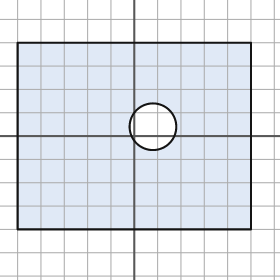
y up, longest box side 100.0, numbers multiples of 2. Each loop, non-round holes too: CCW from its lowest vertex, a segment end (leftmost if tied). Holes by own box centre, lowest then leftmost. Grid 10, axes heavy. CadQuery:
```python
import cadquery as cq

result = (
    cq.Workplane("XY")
    .moveTo(-50.0, -40.0)
    .lineTo(50.0, -40.0)
    .lineTo(50.0, 40.0)
    .lineTo(-50.0, 40.0)
    .close()
    .moveTo(8.0, 4.0)
    .circle(10.0)
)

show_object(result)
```